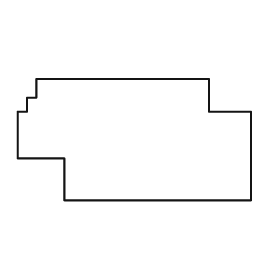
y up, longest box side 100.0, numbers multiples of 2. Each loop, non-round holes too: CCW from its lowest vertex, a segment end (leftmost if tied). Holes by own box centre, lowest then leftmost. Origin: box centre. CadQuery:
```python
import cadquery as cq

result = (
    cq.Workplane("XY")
    .moveTo(-30.0, -26.0)
    .lineTo(50.0, -26.0)
    .lineTo(50.0, 12.0)
    .lineTo(32.0, 12.0)
    .lineTo(32.0, 26.0)
    .lineTo(-42.0, 26.0)
    .lineTo(-42.0, 18.0)
    .lineTo(-46.0, 18.0)
    .lineTo(-46.0, 12.0)
    .lineTo(-50.0, 12.0)
    .lineTo(-50.0, -8.0)
    .lineTo(-30.0, -8.0)
    .close()
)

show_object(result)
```